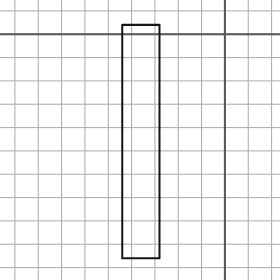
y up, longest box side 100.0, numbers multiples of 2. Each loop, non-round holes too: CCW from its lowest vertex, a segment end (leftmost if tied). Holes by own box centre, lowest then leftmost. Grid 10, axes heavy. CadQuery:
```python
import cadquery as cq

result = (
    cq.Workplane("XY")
    .moveTo(-44.0, -96.0)
    .lineTo(-28.0, -96.0)
    .lineTo(-28.0, 4.0)
    .lineTo(-44.0, 4.0)
    .close()
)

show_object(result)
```